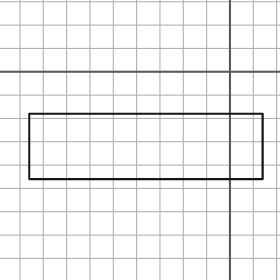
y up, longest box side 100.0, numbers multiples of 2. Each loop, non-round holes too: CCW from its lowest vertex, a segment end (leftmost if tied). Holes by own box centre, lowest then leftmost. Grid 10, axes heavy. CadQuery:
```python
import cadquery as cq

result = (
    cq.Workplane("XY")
    .moveTo(-86.0, -46.0)
    .lineTo(14.0, -46.0)
    .lineTo(14.0, -18.0)
    .lineTo(-86.0, -18.0)
    .close()
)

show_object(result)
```